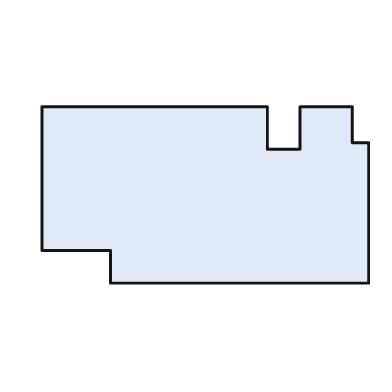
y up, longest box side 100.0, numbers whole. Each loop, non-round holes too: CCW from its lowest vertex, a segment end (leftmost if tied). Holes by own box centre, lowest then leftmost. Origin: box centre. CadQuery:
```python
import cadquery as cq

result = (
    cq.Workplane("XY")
    .moveTo(-29.0, -27.0)
    .lineTo(50.0, -27.0)
    .lineTo(50.0, 16.0)
    .lineTo(45.0, 16.0)
    .lineTo(45.0, 27.0)
    .lineTo(29.0, 27.0)
    .lineTo(29.0, 14.0)
    .lineTo(19.0, 14.0)
    .lineTo(19.0, 27.0)
    .lineTo(-50.0, 27.0)
    .lineTo(-50.0, -17.0)
    .lineTo(-29.0, -17.0)
    .close()
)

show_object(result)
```